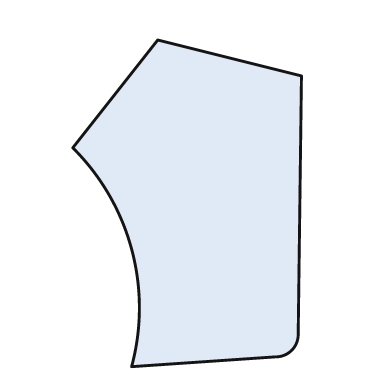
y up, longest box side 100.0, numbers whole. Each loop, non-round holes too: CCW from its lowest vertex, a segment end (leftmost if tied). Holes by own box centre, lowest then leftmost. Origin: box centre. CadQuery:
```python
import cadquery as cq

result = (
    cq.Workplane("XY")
    .moveTo(-17.0, -50.0)
    .lineTo(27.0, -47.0)
    .threePointArc((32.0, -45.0), (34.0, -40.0))
    .lineTo(35.0, 39.0)
    .lineTo(-9.0, 50.0)
    .lineTo(-35.0, 17.0)
    .threePointArc((-17.0, -14.0), (-17.0, -50.0))
    .close()
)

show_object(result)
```